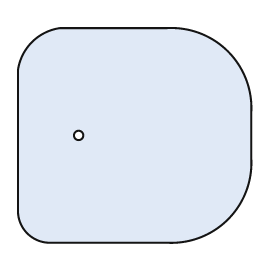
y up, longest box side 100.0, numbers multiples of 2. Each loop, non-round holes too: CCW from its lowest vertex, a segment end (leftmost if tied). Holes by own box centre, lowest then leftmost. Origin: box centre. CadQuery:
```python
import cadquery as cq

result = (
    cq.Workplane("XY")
    .moveTo(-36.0, -46.0)
    .lineTo(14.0, -46.0)
    .threePointArc((40.0, -36.0), (50.0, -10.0))
    .lineTo(50.0, 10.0)
    .threePointArc((40.0, 36.0), (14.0, 46.0))
    .lineTo(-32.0, 46.0)
    .threePointArc((-44.0, 40.0), (-50.0, 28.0))
    .lineTo(-50.0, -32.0)
    .threePointArc((-46.0, -42.0), (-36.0, -46.0))
    .close()
    .moveTo(-24.0, 0.0)
    .circle(2.0)
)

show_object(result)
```